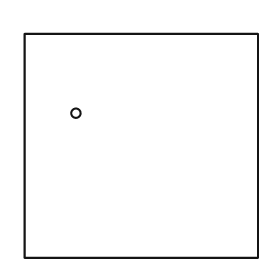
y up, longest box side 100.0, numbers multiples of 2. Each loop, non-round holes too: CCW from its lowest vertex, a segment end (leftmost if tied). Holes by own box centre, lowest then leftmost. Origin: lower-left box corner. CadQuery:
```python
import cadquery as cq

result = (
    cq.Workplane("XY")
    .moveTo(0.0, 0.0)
    .lineTo(100.0, 0.0)
    .lineTo(100.0, 96.0)
    .lineTo(0.0, 96.0)
    .close()
    .moveTo(22.0, 62.0)
    .circle(2.0)
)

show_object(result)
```